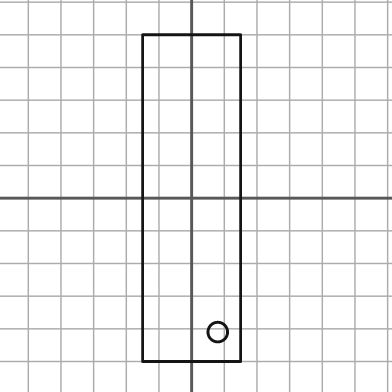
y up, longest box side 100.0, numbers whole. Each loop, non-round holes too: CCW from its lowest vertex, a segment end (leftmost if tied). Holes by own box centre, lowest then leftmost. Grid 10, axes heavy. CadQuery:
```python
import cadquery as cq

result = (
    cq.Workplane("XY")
    .moveTo(-15.0, -50.0)
    .lineTo(15.0, -50.0)
    .lineTo(15.0, 50.0)
    .lineTo(-15.0, 50.0)
    .close()
    .moveTo(8.0, -41.0)
    .circle(3.0)
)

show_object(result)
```